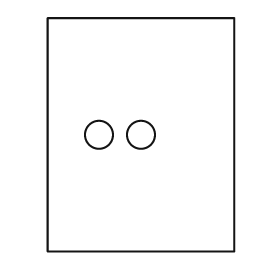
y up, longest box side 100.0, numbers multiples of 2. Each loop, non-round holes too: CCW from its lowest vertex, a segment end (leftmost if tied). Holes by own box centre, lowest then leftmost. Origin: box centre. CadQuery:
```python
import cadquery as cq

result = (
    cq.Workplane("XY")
    .moveTo(-40.0, -50.0)
    .lineTo(40.0, -50.0)
    .lineTo(40.0, 50.0)
    .lineTo(-40.0, 50.0)
    .close()
    .moveTo(-18.0, 0.0)
    .circle(6.0)
    .moveTo(0.0, 0.0)
    .circle(6.0)
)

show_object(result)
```